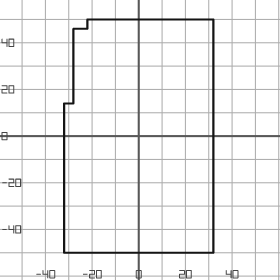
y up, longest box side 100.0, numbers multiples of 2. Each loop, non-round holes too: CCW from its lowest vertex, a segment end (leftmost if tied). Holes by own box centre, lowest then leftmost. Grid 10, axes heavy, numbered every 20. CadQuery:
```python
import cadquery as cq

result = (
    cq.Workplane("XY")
    .moveTo(-32.0, -50.0)
    .lineTo(32.0, -50.0)
    .lineTo(32.0, 50.0)
    .lineTo(-22.0, 50.0)
    .lineTo(-22.0, 46.0)
    .lineTo(-28.0, 46.0)
    .lineTo(-28.0, 14.0)
    .lineTo(-32.0, 14.0)
    .close()
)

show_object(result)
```